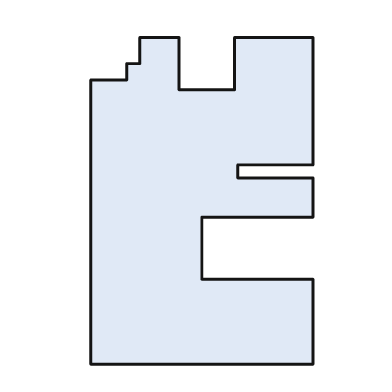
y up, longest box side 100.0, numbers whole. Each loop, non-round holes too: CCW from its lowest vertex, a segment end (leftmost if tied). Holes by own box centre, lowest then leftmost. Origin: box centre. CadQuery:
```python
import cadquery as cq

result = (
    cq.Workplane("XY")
    .moveTo(-34.0, -50.0)
    .lineTo(34.0, -50.0)
    .lineTo(34.0, -24.0)
    .lineTo(0.0, -24.0)
    .lineTo(0.0, -5.0)
    .lineTo(34.0, -5.0)
    .lineTo(34.0, 7.0)
    .lineTo(11.0, 7.0)
    .lineTo(11.0, 11.0)
    .lineTo(34.0, 11.0)
    .lineTo(34.0, 50.0)
    .lineTo(10.0, 50.0)
    .lineTo(10.0, 34.0)
    .lineTo(-7.0, 34.0)
    .lineTo(-7.0, 50.0)
    .lineTo(-19.0, 50.0)
    .lineTo(-19.0, 42.0)
    .lineTo(-23.0, 42.0)
    .lineTo(-23.0, 37.0)
    .lineTo(-34.0, 37.0)
    .close()
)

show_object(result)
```